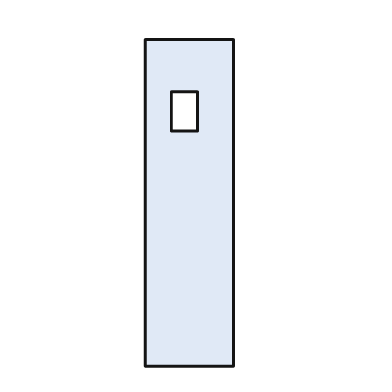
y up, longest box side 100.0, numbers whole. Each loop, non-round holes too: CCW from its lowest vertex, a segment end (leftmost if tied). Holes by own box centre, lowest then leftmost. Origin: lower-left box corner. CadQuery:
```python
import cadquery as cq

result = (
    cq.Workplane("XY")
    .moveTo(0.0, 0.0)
    .lineTo(27.0, 0.0)
    .lineTo(27.0, 100.0)
    .lineTo(0.0, 100.0)
    .close()
    .moveTo(8.0, 72.0)
    .lineTo(16.0, 72.0)
    .lineTo(16.0, 84.0)
    .lineTo(8.0, 84.0)
    .close()
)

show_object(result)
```